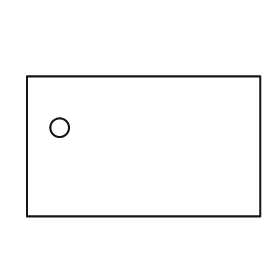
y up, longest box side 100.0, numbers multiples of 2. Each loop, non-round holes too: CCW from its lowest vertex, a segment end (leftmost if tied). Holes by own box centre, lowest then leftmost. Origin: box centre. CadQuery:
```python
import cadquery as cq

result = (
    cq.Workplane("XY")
    .moveTo(-50.0, -30.0)
    .lineTo(50.0, -30.0)
    .lineTo(50.0, 30.0)
    .lineTo(-50.0, 30.0)
    .close()
    .moveTo(-36.0, 8.0)
    .circle(4.0)
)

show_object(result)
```